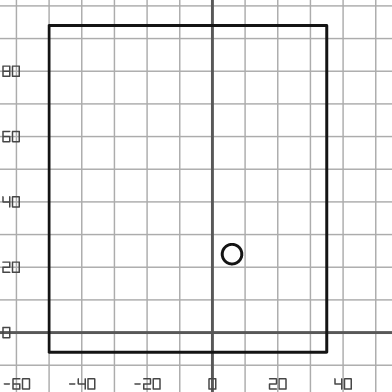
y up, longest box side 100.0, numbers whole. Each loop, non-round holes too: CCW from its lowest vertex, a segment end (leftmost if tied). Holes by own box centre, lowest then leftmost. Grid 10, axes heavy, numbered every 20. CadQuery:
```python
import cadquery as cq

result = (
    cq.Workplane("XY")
    .moveTo(-50.0, -6.0)
    .lineTo(35.0, -6.0)
    .lineTo(35.0, 94.0)
    .lineTo(-50.0, 94.0)
    .close()
    .moveTo(6.0, 24.0)
    .circle(3.0)
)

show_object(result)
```